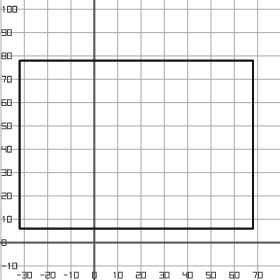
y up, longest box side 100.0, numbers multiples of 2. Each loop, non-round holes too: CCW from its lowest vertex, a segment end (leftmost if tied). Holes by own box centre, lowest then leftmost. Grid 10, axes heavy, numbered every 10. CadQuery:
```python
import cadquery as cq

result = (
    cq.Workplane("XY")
    .moveTo(-32.0, 6.0)
    .lineTo(68.0, 6.0)
    .lineTo(68.0, 78.0)
    .lineTo(-32.0, 78.0)
    .close()
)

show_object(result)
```